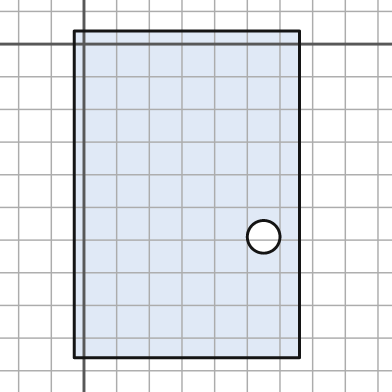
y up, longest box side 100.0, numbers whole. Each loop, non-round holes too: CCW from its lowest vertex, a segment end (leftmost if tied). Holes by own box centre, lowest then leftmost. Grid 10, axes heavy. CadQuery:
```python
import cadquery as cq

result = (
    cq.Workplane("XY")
    .moveTo(-3.0, -96.0)
    .lineTo(66.0, -96.0)
    .lineTo(66.0, 4.0)
    .lineTo(-3.0, 4.0)
    .close()
    .moveTo(55.0, -59.0)
    .circle(5.0)
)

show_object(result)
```